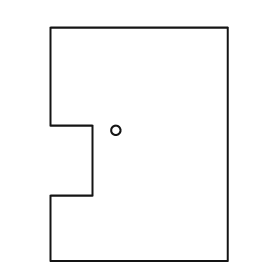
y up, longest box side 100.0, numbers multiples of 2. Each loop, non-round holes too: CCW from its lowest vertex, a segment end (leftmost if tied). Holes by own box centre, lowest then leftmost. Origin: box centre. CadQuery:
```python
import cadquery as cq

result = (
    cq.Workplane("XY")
    .moveTo(-38.0, -50.0)
    .lineTo(38.0, -50.0)
    .lineTo(38.0, 50.0)
    .lineTo(-38.0, 50.0)
    .lineTo(-38.0, 8.0)
    .lineTo(-20.0, 8.0)
    .lineTo(-20.0, -22.0)
    .lineTo(-38.0, -22.0)
    .close()
    .moveTo(-10.0, 6.0)
    .circle(2.0)
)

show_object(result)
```